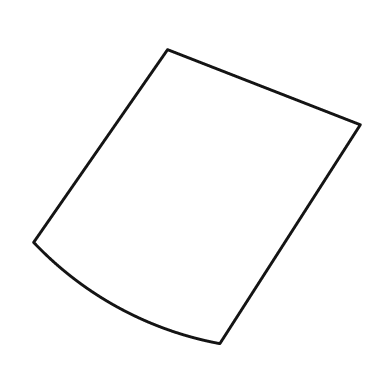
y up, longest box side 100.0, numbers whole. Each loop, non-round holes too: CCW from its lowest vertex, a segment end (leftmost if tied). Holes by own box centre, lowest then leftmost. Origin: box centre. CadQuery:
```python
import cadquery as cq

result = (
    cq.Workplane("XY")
    .moveTo(7.0, -45.0)
    .lineTo(50.0, 22.0)
    .lineTo(-9.0, 45.0)
    .lineTo(-50.0, -14.0)
    .threePointArc((-24.0, -34.0), (7.0, -45.0))
    .close()
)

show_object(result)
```